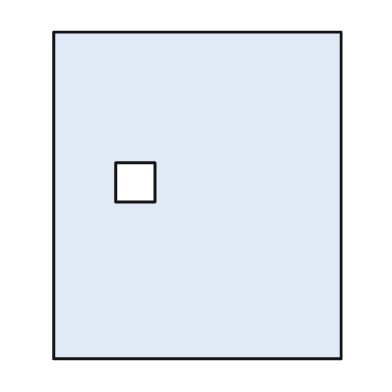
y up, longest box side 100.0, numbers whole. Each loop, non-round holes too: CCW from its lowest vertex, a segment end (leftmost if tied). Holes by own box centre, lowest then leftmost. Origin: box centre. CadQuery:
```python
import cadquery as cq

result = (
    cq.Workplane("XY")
    .moveTo(-44.0, -50.0)
    .lineTo(44.0, -50.0)
    .lineTo(44.0, 50.0)
    .lineTo(-44.0, 50.0)
    .close()
    .moveTo(-25.0, -2.0)
    .lineTo(-13.0, -2.0)
    .lineTo(-13.0, 10.0)
    .lineTo(-25.0, 10.0)
    .close()
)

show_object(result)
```